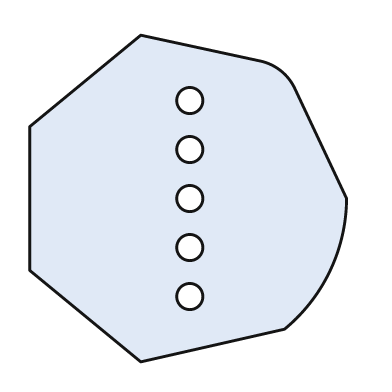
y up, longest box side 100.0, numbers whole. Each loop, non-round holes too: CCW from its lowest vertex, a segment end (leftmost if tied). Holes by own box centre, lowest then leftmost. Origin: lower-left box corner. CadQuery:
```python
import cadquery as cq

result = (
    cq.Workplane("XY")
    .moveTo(34.0, 0.0)
    .lineTo(78.0, 10.0)
    .threePointArc((92.0, 28.0), (97.0, 50.0))
    .lineTo(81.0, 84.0)
    .threePointArc((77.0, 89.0), (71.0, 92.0))
    .lineTo(34.0, 100.0)
    .lineTo(0.0, 72.0)
    .lineTo(0.0, 28.0)
    .close()
    .moveTo(49.0, 20.0)
    .circle(4.0)
    .moveTo(49.0, 35.0)
    .circle(4.0)
    .moveTo(49.0, 50.0)
    .circle(4.0)
    .moveTo(49.0, 65.0)
    .circle(4.0)
    .moveTo(49.0, 80.0)
    .circle(4.0)
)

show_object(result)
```